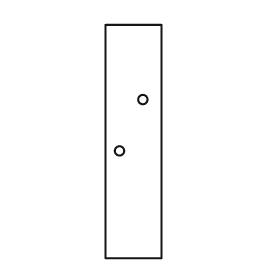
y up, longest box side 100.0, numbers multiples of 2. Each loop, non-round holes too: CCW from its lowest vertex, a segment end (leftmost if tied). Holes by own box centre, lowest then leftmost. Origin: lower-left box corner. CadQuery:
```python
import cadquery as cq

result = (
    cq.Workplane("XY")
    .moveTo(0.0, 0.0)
    .lineTo(24.0, 0.0)
    .lineTo(24.0, 100.0)
    .lineTo(0.0, 100.0)
    .close()
    .moveTo(6.0, 46.0)
    .circle(2.0)
    .moveTo(16.0, 68.0)
    .circle(2.0)
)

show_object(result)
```